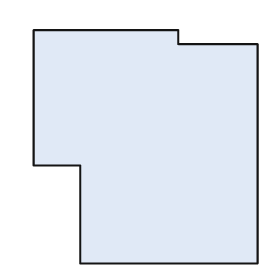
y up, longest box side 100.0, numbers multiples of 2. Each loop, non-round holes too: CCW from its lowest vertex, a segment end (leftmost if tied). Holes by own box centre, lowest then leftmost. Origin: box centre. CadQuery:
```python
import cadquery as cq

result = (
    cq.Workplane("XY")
    .moveTo(-28.0, -50.0)
    .lineTo(48.0, -50.0)
    .lineTo(48.0, 44.0)
    .lineTo(14.0, 44.0)
    .lineTo(14.0, 50.0)
    .lineTo(-48.0, 50.0)
    .lineTo(-48.0, -8.0)
    .lineTo(-28.0, -8.0)
    .close()
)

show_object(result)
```